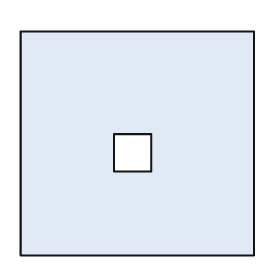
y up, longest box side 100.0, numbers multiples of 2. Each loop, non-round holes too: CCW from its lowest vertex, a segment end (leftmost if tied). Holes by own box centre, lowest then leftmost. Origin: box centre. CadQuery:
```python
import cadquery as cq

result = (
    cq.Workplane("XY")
    .moveTo(-50.0, -48.0)
    .lineTo(50.0, -48.0)
    .lineTo(50.0, 48.0)
    .lineTo(-50.0, 48.0)
    .close()
    .moveTo(-10.0, -12.0)
    .lineTo(6.0, -12.0)
    .lineTo(6.0, 4.0)
    .lineTo(-10.0, 4.0)
    .close()
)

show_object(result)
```